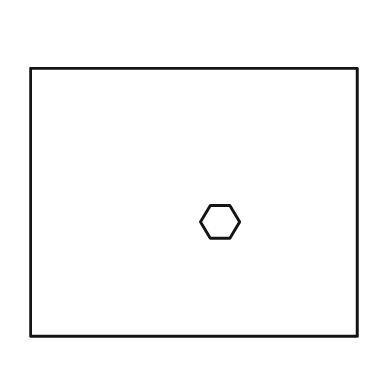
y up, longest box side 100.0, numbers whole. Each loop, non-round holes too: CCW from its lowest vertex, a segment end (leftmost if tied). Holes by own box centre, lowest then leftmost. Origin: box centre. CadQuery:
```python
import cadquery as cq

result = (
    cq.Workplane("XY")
    .moveTo(-50.0, -41.0)
    .lineTo(50.0, -41.0)
    .lineTo(50.0, 41.0)
    .lineTo(-50.0, 41.0)
    .close()
    .moveTo(5.0, -11.0)
    .lineTo(11.0, -11.0)
    .lineTo(14.0, -6.0)
    .lineTo(11.0, -1.0)
    .lineTo(5.0, -1.0)
    .lineTo(2.0, -6.0)
    .close()
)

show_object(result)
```